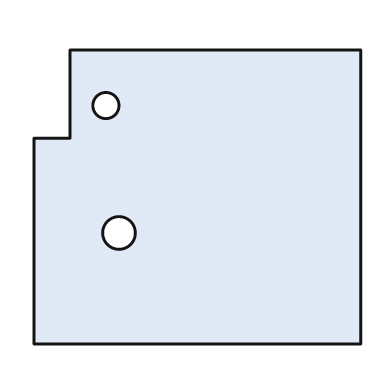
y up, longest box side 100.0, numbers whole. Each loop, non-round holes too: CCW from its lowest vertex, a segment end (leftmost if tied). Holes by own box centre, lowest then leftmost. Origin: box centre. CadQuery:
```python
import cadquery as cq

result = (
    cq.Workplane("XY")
    .moveTo(-50.0, -45.0)
    .lineTo(50.0, -45.0)
    .lineTo(50.0, 45.0)
    .lineTo(-39.0, 45.0)
    .lineTo(-39.0, 18.0)
    .lineTo(-50.0, 18.0)
    .close()
    .moveTo(-24.0, -11.0)
    .circle(5.0)
    .moveTo(-28.0, 28.0)
    .circle(4.0)
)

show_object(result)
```